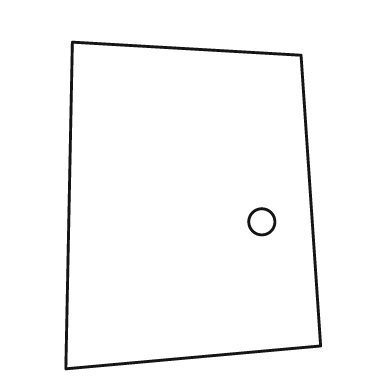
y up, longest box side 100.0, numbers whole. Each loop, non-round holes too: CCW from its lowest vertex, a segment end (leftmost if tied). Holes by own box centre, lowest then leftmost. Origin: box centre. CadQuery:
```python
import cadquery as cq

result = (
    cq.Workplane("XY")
    .moveTo(-39.0, -50.0)
    .lineTo(39.0, -43.0)
    .lineTo(33.0, 46.0)
    .lineTo(-37.0, 50.0)
    .close()
    .moveTo(21.0, -5.0)
    .circle(4.0)
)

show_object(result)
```